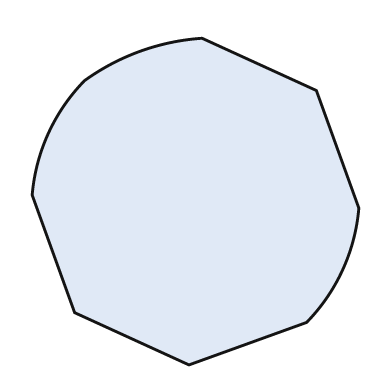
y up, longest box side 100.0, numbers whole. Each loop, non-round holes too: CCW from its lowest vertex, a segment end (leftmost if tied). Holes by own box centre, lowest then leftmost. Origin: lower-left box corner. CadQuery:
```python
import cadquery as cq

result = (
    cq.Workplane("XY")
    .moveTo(48.0, 0.0)
    .lineTo(84.0, 13.0)
    .threePointArc((95.0, 29.0), (100.0, 48.0))
    .lineTo(87.0, 84.0)
    .lineTo(52.0, 100.0)
    .threePointArc((33.0, 96.0), (16.0, 87.0))
    .threePointArc((5.0, 71.0), (0.0, 52.0))
    .lineTo(13.0, 16.0)
    .close()
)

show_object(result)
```